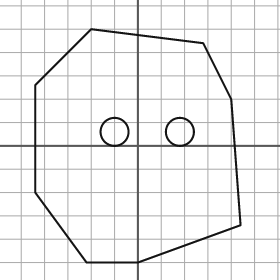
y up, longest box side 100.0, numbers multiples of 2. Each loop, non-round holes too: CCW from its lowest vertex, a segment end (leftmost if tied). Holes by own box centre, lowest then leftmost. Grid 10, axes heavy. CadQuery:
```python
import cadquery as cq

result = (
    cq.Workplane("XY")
    .moveTo(-22.0, -50.0)
    .lineTo(0.0, -50.0)
    .lineTo(44.0, -34.0)
    .lineTo(40.0, 20.0)
    .lineTo(28.0, 44.0)
    .lineTo(-20.0, 50.0)
    .lineTo(-44.0, 26.0)
    .lineTo(-44.0, -20.0)
    .close()
    .moveTo(-10.0, 6.0)
    .circle(6.0)
    .moveTo(18.0, 6.0)
    .circle(6.0)
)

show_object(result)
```